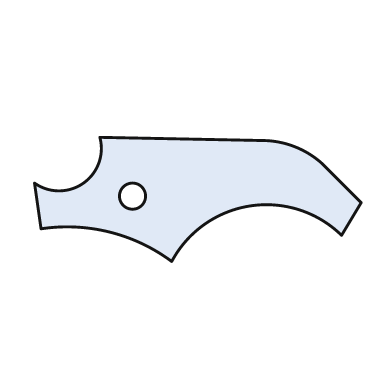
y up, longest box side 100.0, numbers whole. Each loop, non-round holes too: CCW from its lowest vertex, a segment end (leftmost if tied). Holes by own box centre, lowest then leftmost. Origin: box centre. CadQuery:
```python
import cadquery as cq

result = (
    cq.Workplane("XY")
    .moveTo(-8.0, -19.0)
    .threePointArc((16.0, -2.0), (44.0, -11.0))
    .lineTo(50.0, -1.0)
    .lineTo(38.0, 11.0)
    .threePointArc((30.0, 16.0), (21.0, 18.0))
    .lineTo(-30.0, 19.0)
    .threePointArc((-35.0, 5.0), (-50.0, 5.0))
    .lineTo(-48.0, -9.0)
    .threePointArc((-27.0, -10.0), (-8.0, -19.0))
    .close()
    .moveTo(-20.0, 1.0)
    .circle(4.0)
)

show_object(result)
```